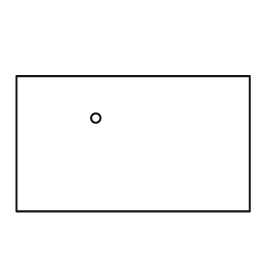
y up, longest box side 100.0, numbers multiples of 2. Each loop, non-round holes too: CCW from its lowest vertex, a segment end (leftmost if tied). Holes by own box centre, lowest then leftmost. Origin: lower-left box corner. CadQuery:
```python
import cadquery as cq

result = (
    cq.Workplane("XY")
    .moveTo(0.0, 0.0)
    .lineTo(100.0, 0.0)
    .lineTo(100.0, 58.0)
    .lineTo(0.0, 58.0)
    .close()
    .moveTo(34.0, 40.0)
    .circle(2.0)
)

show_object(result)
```